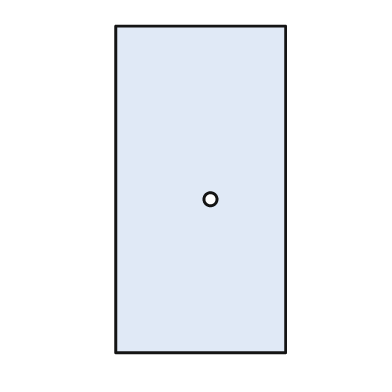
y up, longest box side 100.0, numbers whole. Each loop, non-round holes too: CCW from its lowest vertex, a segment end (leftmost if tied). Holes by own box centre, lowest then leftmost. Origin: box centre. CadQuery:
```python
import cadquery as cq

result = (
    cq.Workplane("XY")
    .moveTo(-26.0, -50.0)
    .lineTo(26.0, -50.0)
    .lineTo(26.0, 50.0)
    .lineTo(-26.0, 50.0)
    .close()
    .moveTo(3.0, -3.0)
    .circle(2.0)
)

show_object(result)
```